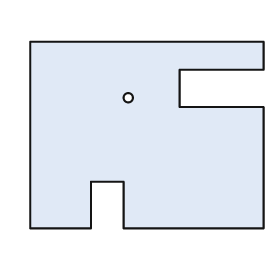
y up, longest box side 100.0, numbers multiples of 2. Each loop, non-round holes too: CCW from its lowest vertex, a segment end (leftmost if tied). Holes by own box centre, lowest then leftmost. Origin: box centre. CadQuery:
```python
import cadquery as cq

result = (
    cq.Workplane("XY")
    .moveTo(-50.0, -40.0)
    .lineTo(-24.0, -40.0)
    .lineTo(-24.0, -20.0)
    .lineTo(-10.0, -20.0)
    .lineTo(-10.0, -40.0)
    .lineTo(50.0, -40.0)
    .lineTo(50.0, 12.0)
    .lineTo(14.0, 12.0)
    .lineTo(14.0, 28.0)
    .lineTo(50.0, 28.0)
    .lineTo(50.0, 40.0)
    .lineTo(-50.0, 40.0)
    .close()
    .moveTo(-8.0, 16.0)
    .circle(2.0)
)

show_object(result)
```